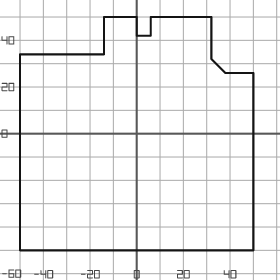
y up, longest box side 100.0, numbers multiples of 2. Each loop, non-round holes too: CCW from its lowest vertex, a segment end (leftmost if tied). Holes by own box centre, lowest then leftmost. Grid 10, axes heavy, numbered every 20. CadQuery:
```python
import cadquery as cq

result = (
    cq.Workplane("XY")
    .moveTo(-50.0, -50.0)
    .lineTo(50.0, -50.0)
    .lineTo(50.0, 26.0)
    .lineTo(38.0, 26.0)
    .lineTo(32.0, 32.0)
    .lineTo(32.0, 50.0)
    .lineTo(6.0, 50.0)
    .lineTo(6.0, 42.0)
    .lineTo(0.0, 42.0)
    .lineTo(0.0, 50.0)
    .lineTo(-14.0, 50.0)
    .lineTo(-14.0, 34.0)
    .lineTo(-50.0, 34.0)
    .close()
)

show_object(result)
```